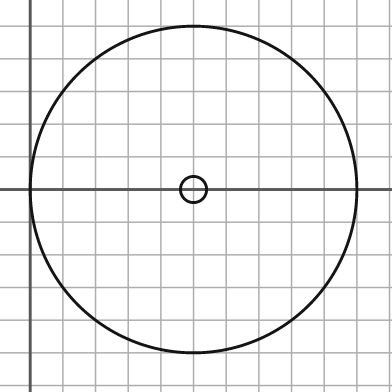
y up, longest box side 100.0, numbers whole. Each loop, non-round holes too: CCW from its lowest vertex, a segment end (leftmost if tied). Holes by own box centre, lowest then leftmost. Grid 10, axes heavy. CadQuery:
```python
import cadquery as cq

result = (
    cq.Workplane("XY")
    .moveTo(50.0, 0.0)
    .circle(50.0)
    .moveTo(50.0, 0.0)
    .circle(4.0)
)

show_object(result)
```